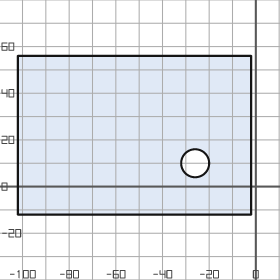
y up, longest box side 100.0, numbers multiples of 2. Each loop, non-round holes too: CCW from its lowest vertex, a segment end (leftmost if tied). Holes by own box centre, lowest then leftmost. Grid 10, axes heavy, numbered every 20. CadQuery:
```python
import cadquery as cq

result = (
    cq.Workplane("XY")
    .moveTo(-102.0, -12.0)
    .lineTo(-2.0, -12.0)
    .lineTo(-2.0, 56.0)
    .lineTo(-102.0, 56.0)
    .close()
    .moveTo(-26.0, 10.0)
    .circle(6.0)
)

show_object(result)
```